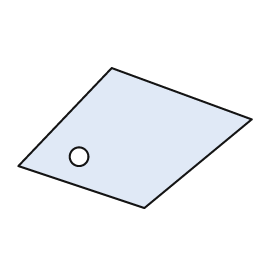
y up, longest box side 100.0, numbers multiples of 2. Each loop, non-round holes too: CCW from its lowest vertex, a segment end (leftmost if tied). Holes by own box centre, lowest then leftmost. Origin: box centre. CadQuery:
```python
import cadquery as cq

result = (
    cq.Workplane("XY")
    .moveTo(4.0, -30.0)
    .lineTo(50.0, 8.0)
    .lineTo(-10.0, 30.0)
    .lineTo(-50.0, -12.0)
    .close()
    .moveTo(-24.0, -8.0)
    .circle(4.0)
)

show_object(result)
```